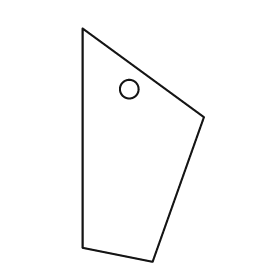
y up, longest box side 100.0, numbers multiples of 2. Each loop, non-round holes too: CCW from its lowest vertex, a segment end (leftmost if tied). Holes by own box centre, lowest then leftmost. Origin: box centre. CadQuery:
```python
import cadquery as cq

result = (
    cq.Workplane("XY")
    .moveTo(4.0, -50.0)
    .lineTo(26.0, 12.0)
    .lineTo(-26.0, 50.0)
    .lineTo(-26.0, -44.0)
    .close()
    .moveTo(-6.0, 24.0)
    .circle(4.0)
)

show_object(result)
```